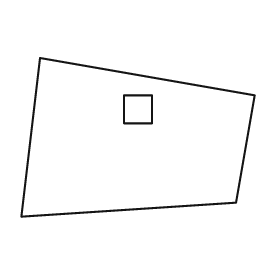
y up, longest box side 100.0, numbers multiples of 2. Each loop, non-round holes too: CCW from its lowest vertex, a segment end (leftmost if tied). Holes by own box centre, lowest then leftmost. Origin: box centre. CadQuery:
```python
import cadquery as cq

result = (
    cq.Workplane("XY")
    .moveTo(-50.0, -34.0)
    .lineTo(42.0, -28.0)
    .lineTo(50.0, 18.0)
    .lineTo(-42.0, 34.0)
    .close()
    .moveTo(-6.0, 6.0)
    .lineTo(6.0, 6.0)
    .lineTo(6.0, 18.0)
    .lineTo(-6.0, 18.0)
    .close()
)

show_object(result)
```